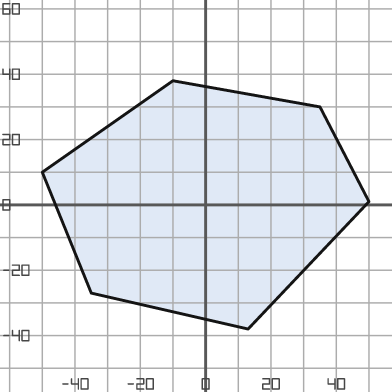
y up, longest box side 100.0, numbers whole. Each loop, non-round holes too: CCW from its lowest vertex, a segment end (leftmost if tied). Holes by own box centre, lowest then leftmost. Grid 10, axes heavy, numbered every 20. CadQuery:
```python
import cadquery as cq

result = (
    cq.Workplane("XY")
    .moveTo(13.0, -38.0)
    .lineTo(50.0, 1.0)
    .lineTo(35.0, 30.0)
    .lineTo(-10.0, 38.0)
    .lineTo(-50.0, 10.0)
    .lineTo(-35.0, -27.0)
    .close()
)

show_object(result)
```